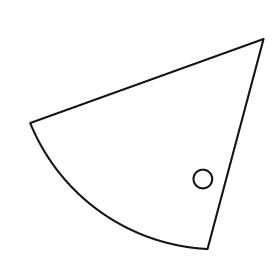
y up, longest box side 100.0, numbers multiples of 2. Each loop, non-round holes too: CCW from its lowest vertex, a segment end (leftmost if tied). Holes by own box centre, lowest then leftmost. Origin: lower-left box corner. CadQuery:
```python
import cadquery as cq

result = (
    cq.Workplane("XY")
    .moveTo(76.0, 0.0)
    .lineTo(100.0, 90.0)
    .lineTo(0.0, 54.0)
    .threePointArc((30.0, 16.0), (76.0, 0.0))
    .close()
    .moveTo(74.0, 30.0)
    .circle(4.0)
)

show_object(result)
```